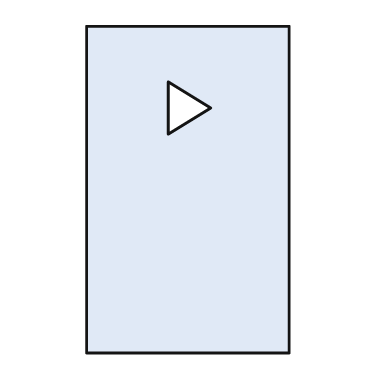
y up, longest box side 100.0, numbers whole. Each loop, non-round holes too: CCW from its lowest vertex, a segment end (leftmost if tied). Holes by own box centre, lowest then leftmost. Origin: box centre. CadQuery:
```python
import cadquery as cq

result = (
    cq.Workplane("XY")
    .moveTo(-31.0, -50.0)
    .lineTo(31.0, -50.0)
    .lineTo(31.0, 50.0)
    .lineTo(-31.0, 50.0)
    .close()
    .moveTo(-6.0, 17.0)
    .lineTo(7.0, 25.0)
    .lineTo(-6.0, 33.0)
    .close()
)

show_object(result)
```